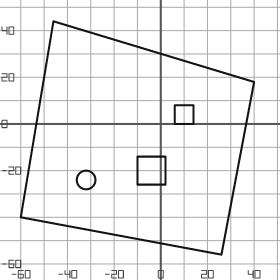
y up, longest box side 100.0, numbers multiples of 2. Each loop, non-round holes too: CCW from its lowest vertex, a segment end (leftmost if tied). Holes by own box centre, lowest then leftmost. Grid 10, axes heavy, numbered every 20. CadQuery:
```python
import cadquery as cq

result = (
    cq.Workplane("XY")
    .moveTo(26.0, -56.0)
    .lineTo(40.0, 18.0)
    .lineTo(-46.0, 44.0)
    .lineTo(-60.0, -40.0)
    .close()
    .moveTo(-32.0, -24.0)
    .circle(4.0)
    .moveTo(-10.0, -26.0)
    .lineTo(2.0, -26.0)
    .lineTo(2.0, -14.0)
    .lineTo(-10.0, -14.0)
    .close()
    .moveTo(6.0, 0.0)
    .lineTo(14.0, 0.0)
    .lineTo(14.0, 8.0)
    .lineTo(6.0, 8.0)
    .close()
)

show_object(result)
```